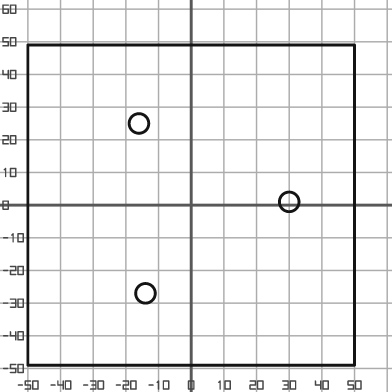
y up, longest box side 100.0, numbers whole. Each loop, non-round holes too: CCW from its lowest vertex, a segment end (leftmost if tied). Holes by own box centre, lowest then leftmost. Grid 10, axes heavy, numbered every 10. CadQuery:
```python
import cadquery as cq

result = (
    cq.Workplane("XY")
    .moveTo(-50.0, -49.0)
    .lineTo(50.0, -49.0)
    .lineTo(50.0, 49.0)
    .lineTo(-50.0, 49.0)
    .close()
    .moveTo(-14.0, -27.0)
    .circle(3.0)
    .moveTo(30.0, 1.0)
    .circle(3.0)
    .moveTo(-16.0, 25.0)
    .circle(3.0)
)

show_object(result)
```